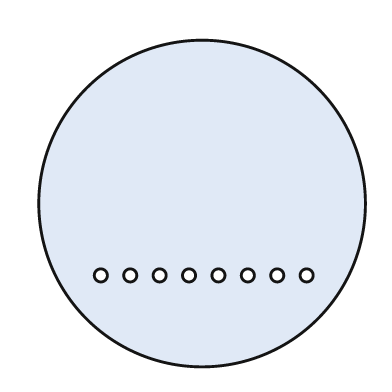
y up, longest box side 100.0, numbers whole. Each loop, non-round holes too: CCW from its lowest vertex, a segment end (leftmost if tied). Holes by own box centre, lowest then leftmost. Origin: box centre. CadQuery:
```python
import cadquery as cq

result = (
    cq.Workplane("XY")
    .moveTo(0.0, 0.0)
    .circle(50.0)
    .moveTo(-31.0, -22.0)
    .circle(2.0)
    .moveTo(-22.0, -22.0)
    .circle(2.0)
    .moveTo(-13.0, -22.0)
    .circle(2.0)
    .moveTo(-4.0, -22.0)
    .circle(2.0)
    .moveTo(5.0, -22.0)
    .circle(2.0)
    .moveTo(14.0, -22.0)
    .circle(2.0)
    .moveTo(23.0, -22.0)
    .circle(2.0)
    .moveTo(32.0, -22.0)
    .circle(2.0)
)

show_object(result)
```